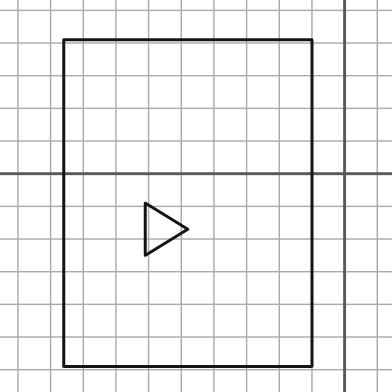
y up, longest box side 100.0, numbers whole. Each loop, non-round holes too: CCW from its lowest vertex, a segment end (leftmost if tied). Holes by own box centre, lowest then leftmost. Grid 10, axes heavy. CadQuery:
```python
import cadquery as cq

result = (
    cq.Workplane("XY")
    .moveTo(-86.0, -59.0)
    .lineTo(-10.0, -59.0)
    .lineTo(-10.0, 41.0)
    .lineTo(-86.0, 41.0)
    .close()
    .moveTo(-61.0, -25.0)
    .lineTo(-48.0, -17.0)
    .lineTo(-61.0, -9.0)
    .close()
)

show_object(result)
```